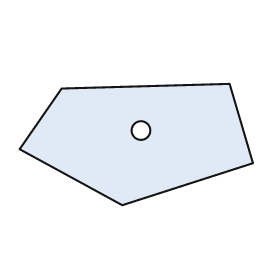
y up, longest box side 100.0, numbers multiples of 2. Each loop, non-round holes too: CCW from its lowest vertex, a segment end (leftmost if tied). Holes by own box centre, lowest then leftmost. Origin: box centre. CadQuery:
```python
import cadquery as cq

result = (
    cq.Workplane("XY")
    .moveTo(-6.0, -26.0)
    .lineTo(50.0, -8.0)
    .lineTo(40.0, 26.0)
    .lineTo(-32.0, 24.0)
    .lineTo(-50.0, -2.0)
    .close()
    .moveTo(2.0, 6.0)
    .circle(4.0)
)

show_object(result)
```